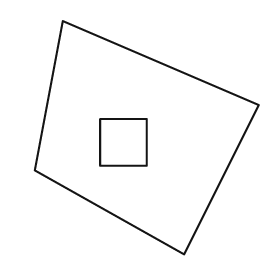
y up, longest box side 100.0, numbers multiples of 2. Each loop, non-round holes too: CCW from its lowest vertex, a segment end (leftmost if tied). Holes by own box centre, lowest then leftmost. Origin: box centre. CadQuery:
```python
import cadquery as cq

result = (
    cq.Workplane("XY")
    .moveTo(16.0, -50.0)
    .lineTo(48.0, 14.0)
    .lineTo(-36.0, 50.0)
    .lineTo(-48.0, -14.0)
    .close()
    .moveTo(-20.0, -12.0)
    .lineTo(0.0, -12.0)
    .lineTo(0.0, 8.0)
    .lineTo(-20.0, 8.0)
    .close()
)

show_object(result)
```